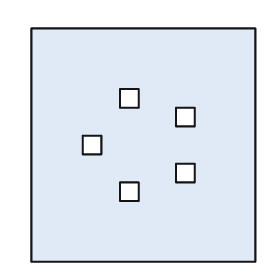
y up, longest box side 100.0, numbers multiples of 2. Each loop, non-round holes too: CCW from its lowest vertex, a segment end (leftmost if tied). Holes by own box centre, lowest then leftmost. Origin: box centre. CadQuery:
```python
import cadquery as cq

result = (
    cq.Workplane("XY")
    .moveTo(-48.0, -50.0)
    .lineTo(48.0, -50.0)
    .lineTo(48.0, 50.0)
    .lineTo(-48.0, 50.0)
    .close()
    .moveTo(-10.0, -24.0)
    .lineTo(-2.0, -24.0)
    .lineTo(-2.0, -16.0)
    .lineTo(-10.0, -16.0)
    .close()
    .moveTo(14.0, -16.0)
    .lineTo(22.0, -16.0)
    .lineTo(22.0, -8.0)
    .lineTo(14.0, -8.0)
    .close()
    .moveTo(-26.0, -4.0)
    .lineTo(-18.0, -4.0)
    .lineTo(-18.0, 4.0)
    .lineTo(-26.0, 4.0)
    .close()
    .moveTo(14.0, 8.0)
    .lineTo(22.0, 8.0)
    .lineTo(22.0, 16.0)
    .lineTo(14.0, 16.0)
    .close()
    .moveTo(-10.0, 16.0)
    .lineTo(-2.0, 16.0)
    .lineTo(-2.0, 24.0)
    .lineTo(-10.0, 24.0)
    .close()
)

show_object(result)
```